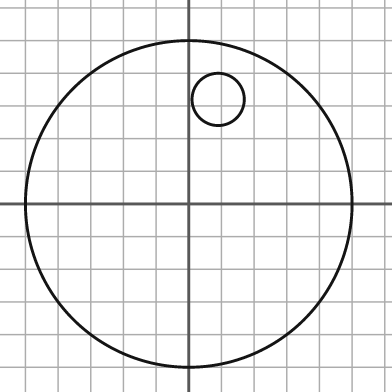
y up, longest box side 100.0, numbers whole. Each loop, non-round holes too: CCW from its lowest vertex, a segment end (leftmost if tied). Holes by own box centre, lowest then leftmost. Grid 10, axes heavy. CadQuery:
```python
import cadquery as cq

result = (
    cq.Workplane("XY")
    .moveTo(0.0, 0.0)
    .circle(50.0)
    .moveTo(9.0, 32.0)
    .circle(8.0)
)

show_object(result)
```